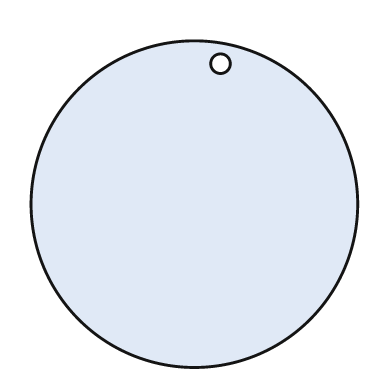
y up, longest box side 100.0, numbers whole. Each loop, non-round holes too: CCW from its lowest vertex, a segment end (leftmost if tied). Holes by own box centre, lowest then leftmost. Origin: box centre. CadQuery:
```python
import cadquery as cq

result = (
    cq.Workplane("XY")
    .moveTo(0.0, 0.0)
    .circle(50.0)
    .moveTo(8.0, 43.0)
    .circle(3.0)
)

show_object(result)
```